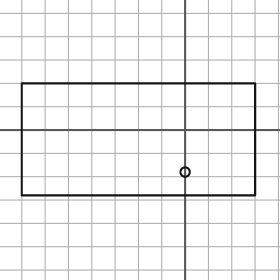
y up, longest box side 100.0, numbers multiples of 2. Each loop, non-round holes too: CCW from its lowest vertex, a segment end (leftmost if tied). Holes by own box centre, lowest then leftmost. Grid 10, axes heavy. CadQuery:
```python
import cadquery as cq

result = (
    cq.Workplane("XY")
    .moveTo(-70.0, -28.0)
    .lineTo(30.0, -28.0)
    .lineTo(30.0, 20.0)
    .lineTo(-70.0, 20.0)
    .close()
    .moveTo(0.0, -18.0)
    .circle(2.0)
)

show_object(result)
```